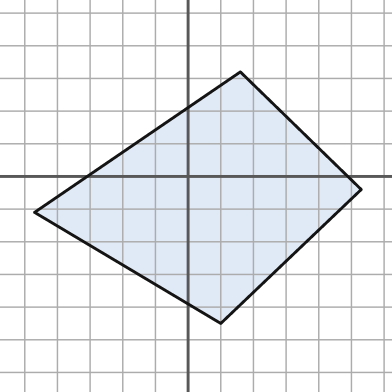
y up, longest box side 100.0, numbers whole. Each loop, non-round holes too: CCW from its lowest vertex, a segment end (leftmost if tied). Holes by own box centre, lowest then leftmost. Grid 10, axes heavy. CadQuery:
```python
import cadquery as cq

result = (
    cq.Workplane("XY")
    .moveTo(10.0, -45.0)
    .lineTo(53.0, -4.0)
    .lineTo(16.0, 32.0)
    .lineTo(-47.0, -11.0)
    .close()
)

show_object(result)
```